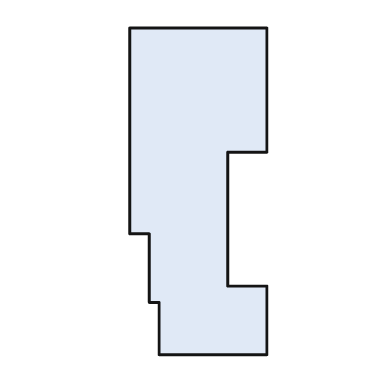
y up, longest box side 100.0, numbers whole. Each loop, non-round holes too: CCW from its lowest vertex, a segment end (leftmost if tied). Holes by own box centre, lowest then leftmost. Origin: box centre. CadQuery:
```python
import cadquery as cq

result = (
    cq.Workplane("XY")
    .moveTo(-12.0, -50.0)
    .lineTo(21.0, -50.0)
    .lineTo(21.0, -29.0)
    .lineTo(9.0, -29.0)
    .lineTo(9.0, 12.0)
    .lineTo(21.0, 12.0)
    .lineTo(21.0, 50.0)
    .lineTo(-21.0, 50.0)
    .lineTo(-21.0, -13.0)
    .lineTo(-15.0, -13.0)
    .lineTo(-15.0, -34.0)
    .lineTo(-12.0, -34.0)
    .close()
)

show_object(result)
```